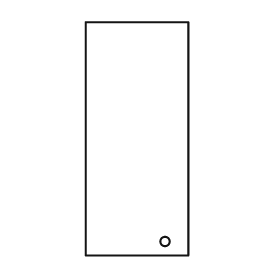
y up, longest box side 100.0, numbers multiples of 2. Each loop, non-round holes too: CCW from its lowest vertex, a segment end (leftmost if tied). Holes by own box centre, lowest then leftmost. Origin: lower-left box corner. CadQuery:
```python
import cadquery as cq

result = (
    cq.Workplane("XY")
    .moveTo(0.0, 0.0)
    .lineTo(44.0, 0.0)
    .lineTo(44.0, 100.0)
    .lineTo(0.0, 100.0)
    .close()
    .moveTo(34.0, 6.0)
    .circle(2.0)
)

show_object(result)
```